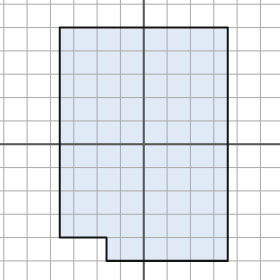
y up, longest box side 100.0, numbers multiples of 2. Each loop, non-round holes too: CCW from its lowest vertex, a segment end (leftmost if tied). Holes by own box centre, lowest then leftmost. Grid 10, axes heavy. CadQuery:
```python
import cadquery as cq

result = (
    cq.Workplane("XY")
    .moveTo(-16.0, -50.0)
    .lineTo(36.0, -50.0)
    .lineTo(36.0, 50.0)
    .lineTo(-36.0, 50.0)
    .lineTo(-36.0, -40.0)
    .lineTo(-16.0, -40.0)
    .close()
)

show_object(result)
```